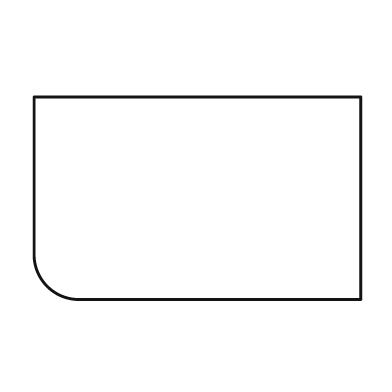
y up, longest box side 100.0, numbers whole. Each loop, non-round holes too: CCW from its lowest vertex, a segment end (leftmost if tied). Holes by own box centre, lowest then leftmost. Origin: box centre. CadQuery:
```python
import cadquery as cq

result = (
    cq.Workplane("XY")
    .moveTo(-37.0, -31.0)
    .lineTo(50.0, -31.0)
    .lineTo(50.0, 31.0)
    .lineTo(-50.0, 31.0)
    .lineTo(-50.0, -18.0)
    .threePointArc((-46.0, -27.0), (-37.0, -31.0))
    .close()
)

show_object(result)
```